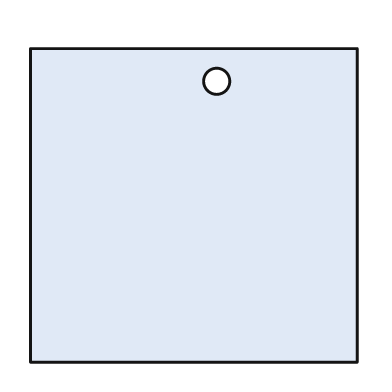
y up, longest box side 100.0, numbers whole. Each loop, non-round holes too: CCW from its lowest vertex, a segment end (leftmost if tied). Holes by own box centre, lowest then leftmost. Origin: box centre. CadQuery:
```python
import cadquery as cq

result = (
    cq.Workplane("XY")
    .moveTo(-50.0, -48.0)
    .lineTo(50.0, -48.0)
    .lineTo(50.0, 48.0)
    .lineTo(-50.0, 48.0)
    .close()
    .moveTo(7.0, 38.0)
    .circle(4.0)
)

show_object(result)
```